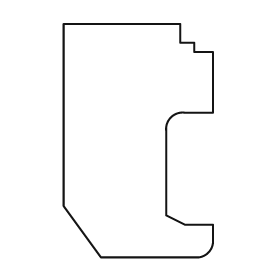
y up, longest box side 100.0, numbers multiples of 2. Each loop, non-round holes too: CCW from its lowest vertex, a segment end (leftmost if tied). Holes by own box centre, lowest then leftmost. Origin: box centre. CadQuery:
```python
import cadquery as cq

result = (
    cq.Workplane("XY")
    .moveTo(-16.0, -50.0)
    .lineTo(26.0, -50.0)
    .threePointArc((30.0, -48.0), (32.0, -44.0))
    .lineTo(32.0, -36.0)
    .lineTo(20.0, -36.0)
    .lineTo(12.0, -32.0)
    .lineTo(12.0, 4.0)
    .threePointArc((14.0, 10.0), (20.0, 12.0))
    .lineTo(32.0, 12.0)
    .lineTo(32.0, 38.0)
    .lineTo(24.0, 38.0)
    .lineTo(24.0, 42.0)
    .lineTo(18.0, 42.0)
    .lineTo(18.0, 50.0)
    .lineTo(-32.0, 50.0)
    .lineTo(-32.0, -28.0)
    .close()
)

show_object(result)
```